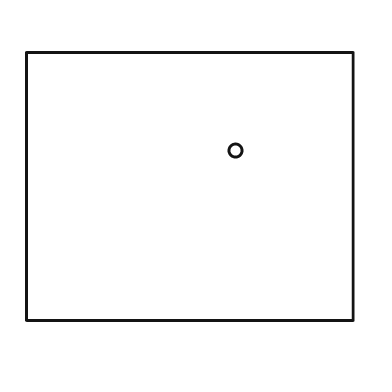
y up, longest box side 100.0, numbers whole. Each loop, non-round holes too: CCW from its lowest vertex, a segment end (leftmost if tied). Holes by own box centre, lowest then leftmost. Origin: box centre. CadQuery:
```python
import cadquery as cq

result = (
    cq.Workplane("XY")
    .moveTo(-50.0, -41.0)
    .lineTo(50.0, -41.0)
    .lineTo(50.0, 41.0)
    .lineTo(-50.0, 41.0)
    .close()
    .moveTo(14.0, 11.0)
    .circle(2.0)
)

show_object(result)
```